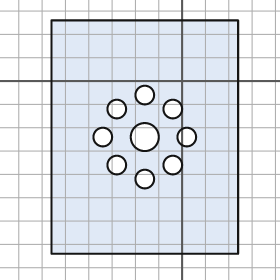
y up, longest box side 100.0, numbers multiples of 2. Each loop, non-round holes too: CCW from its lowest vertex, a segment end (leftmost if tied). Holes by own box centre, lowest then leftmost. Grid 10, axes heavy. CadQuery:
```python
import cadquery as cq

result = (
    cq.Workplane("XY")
    .moveTo(-56.0, -74.0)
    .lineTo(24.0, -74.0)
    .lineTo(24.0, 26.0)
    .lineTo(-56.0, 26.0)
    .close()
    .moveTo(-16.0, -42.0)
    .circle(4.0)
    .moveTo(-28.0, -36.0)
    .circle(4.0)
    .moveTo(-4.0, -36.0)
    .circle(4.0)
    .moveTo(-34.0, -24.0)
    .circle(4.0)
    .moveTo(-16.0, -24.0)
    .circle(6.0)
    .moveTo(2.0, -24.0)
    .circle(4.0)
    .moveTo(-28.0, -12.0)
    .circle(4.0)
    .moveTo(-4.0, -12.0)
    .circle(4.0)
    .moveTo(-16.0, -6.0)
    .circle(4.0)
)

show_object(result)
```